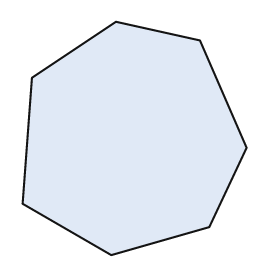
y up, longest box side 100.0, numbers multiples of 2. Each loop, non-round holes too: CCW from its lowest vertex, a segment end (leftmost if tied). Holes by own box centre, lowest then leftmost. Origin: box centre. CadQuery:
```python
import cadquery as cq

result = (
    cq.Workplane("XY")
    .moveTo(-10.0, -50.0)
    .lineTo(32.0, -38.0)
    .lineTo(48.0, -4.0)
    .lineTo(28.0, 42.0)
    .lineTo(-8.0, 50.0)
    .lineTo(-44.0, 26.0)
    .lineTo(-48.0, -28.0)
    .close()
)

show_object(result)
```